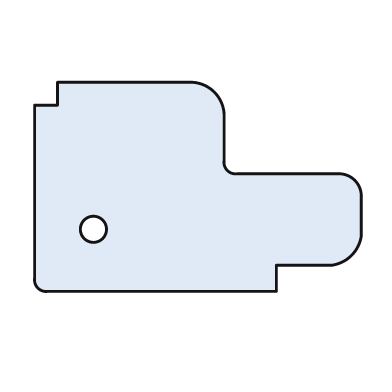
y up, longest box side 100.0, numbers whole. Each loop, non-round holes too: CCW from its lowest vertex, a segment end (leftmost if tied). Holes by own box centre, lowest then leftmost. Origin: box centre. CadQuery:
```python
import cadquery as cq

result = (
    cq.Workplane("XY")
    .moveTo(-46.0, -32.0)
    .lineTo(24.0, -32.0)
    .lineTo(24.0, -24.0)
    .lineTo(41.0, -24.0)
    .threePointArc((47.0, -21.0), (50.0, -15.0))
    .lineTo(50.0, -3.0)
    .threePointArc((48.0, 2.0), (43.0, 4.0))
    .lineTo(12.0, 4.0)
    .threePointArc((9.0, 5.0), (8.0, 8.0))
    .lineTo(8.0, 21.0)
    .threePointArc((5.0, 29.0), (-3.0, 32.0))
    .lineTo(-43.0, 32.0)
    .lineTo(-43.0, 25.0)
    .lineTo(-50.0, 25.0)
    .lineTo(-50.0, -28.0)
    .threePointArc((-49.0, -31.0), (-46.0, -32.0))
    .close()
    .moveTo(-32.0, -13.0)
    .circle(4.0)
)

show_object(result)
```